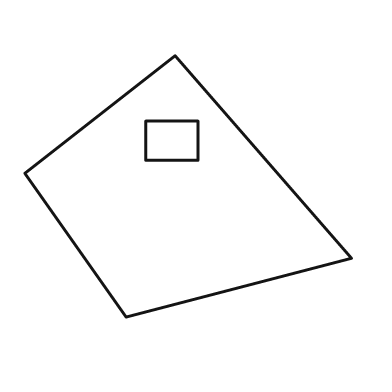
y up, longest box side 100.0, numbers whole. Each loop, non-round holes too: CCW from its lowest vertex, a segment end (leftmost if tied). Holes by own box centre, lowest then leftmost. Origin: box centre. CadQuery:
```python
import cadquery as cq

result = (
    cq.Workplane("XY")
    .moveTo(-19.0, -40.0)
    .lineTo(50.0, -22.0)
    .lineTo(-4.0, 40.0)
    .lineTo(-50.0, 4.0)
    .close()
    .moveTo(-13.0, 8.0)
    .lineTo(3.0, 8.0)
    .lineTo(3.0, 20.0)
    .lineTo(-13.0, 20.0)
    .close()
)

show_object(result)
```